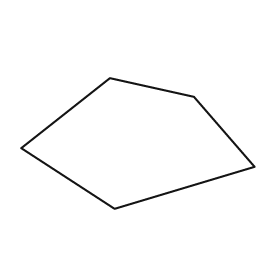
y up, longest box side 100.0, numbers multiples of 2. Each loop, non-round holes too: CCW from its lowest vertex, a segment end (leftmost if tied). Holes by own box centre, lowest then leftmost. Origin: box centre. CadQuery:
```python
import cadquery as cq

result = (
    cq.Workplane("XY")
    .moveTo(-10.0, -28.0)
    .lineTo(50.0, -10.0)
    .lineTo(24.0, 20.0)
    .lineTo(-12.0, 28.0)
    .lineTo(-50.0, -2.0)
    .close()
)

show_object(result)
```